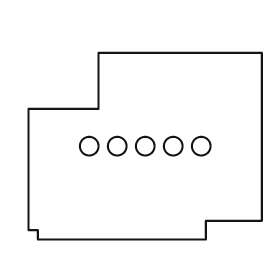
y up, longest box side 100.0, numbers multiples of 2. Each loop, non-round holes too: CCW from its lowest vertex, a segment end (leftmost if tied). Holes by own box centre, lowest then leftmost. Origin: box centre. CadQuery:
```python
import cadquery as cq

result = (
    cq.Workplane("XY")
    .moveTo(-46.0, -40.0)
    .lineTo(26.0, -40.0)
    .lineTo(26.0, -32.0)
    .lineTo(50.0, -32.0)
    .lineTo(50.0, 40.0)
    .lineTo(-20.0, 40.0)
    .lineTo(-20.0, 16.0)
    .lineTo(-50.0, 16.0)
    .lineTo(-50.0, -36.0)
    .lineTo(-46.0, -36.0)
    .close()
    .moveTo(-24.0, 0.0)
    .circle(4.0)
    .moveTo(-12.0, 0.0)
    .circle(4.0)
    .moveTo(0.0, 0.0)
    .circle(4.0)
    .moveTo(12.0, 0.0)
    .circle(4.0)
    .moveTo(24.0, 0.0)
    .circle(4.0)
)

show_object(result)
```